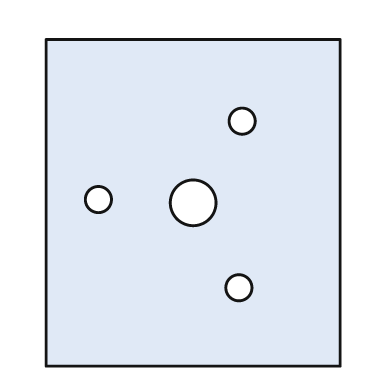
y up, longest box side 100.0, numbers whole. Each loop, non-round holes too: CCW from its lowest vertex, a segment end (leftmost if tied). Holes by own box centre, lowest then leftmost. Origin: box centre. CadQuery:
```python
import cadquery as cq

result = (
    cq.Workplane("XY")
    .moveTo(-45.0, -50.0)
    .lineTo(45.0, -50.0)
    .lineTo(45.0, 50.0)
    .lineTo(-45.0, 50.0)
    .close()
    .moveTo(14.0, -26.0)
    .circle(4.0)
    .moveTo(0.0, 0.0)
    .circle(7.0)
    .moveTo(-29.0, 1.0)
    .circle(4.0)
    .moveTo(15.0, 25.0)
    .circle(4.0)
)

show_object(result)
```